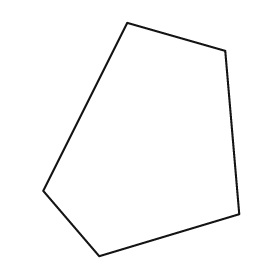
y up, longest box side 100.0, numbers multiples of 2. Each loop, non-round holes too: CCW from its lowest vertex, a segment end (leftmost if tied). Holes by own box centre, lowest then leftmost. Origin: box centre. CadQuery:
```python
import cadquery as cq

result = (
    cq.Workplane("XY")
    .moveTo(-18.0, -50.0)
    .lineTo(42.0, -32.0)
    .lineTo(36.0, 38.0)
    .lineTo(-6.0, 50.0)
    .lineTo(-42.0, -22.0)
    .close()
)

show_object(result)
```